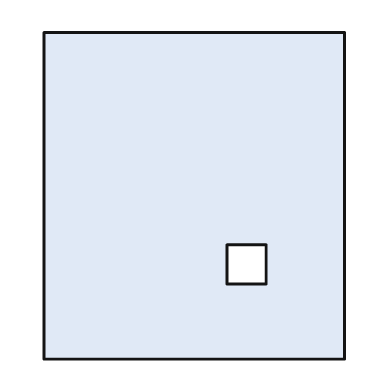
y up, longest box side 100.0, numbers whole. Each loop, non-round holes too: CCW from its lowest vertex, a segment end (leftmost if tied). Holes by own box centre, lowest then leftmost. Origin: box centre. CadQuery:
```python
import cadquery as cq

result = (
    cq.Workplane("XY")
    .moveTo(-46.0, -50.0)
    .lineTo(46.0, -50.0)
    .lineTo(46.0, 50.0)
    .lineTo(-46.0, 50.0)
    .close()
    .moveTo(10.0, -27.0)
    .lineTo(22.0, -27.0)
    .lineTo(22.0, -15.0)
    .lineTo(10.0, -15.0)
    .close()
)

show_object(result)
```